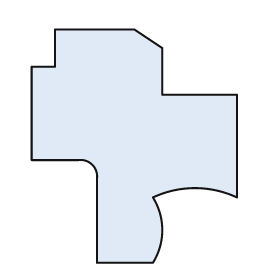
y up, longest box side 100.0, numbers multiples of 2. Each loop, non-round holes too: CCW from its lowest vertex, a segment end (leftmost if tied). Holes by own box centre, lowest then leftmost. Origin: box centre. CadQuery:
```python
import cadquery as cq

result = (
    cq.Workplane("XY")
    .moveTo(-16.0, -50.0)
    .lineTo(8.0, -50.0)
    .threePointArc((12.0, -36.0), (8.0, -22.0))
    .threePointArc((26.0, -18.0), (44.0, -22.0))
    .lineTo(44.0, 22.0)
    .lineTo(12.0, 22.0)
    .lineTo(12.0, 42.0)
    .lineTo(0.0, 50.0)
    .lineTo(-34.0, 50.0)
    .lineTo(-34.0, 34.0)
    .lineTo(-44.0, 34.0)
    .lineTo(-44.0, -6.0)
    .lineTo(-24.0, -6.0)
    .threePointArc((-18.0, -8.0), (-16.0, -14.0))
    .close()
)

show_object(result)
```